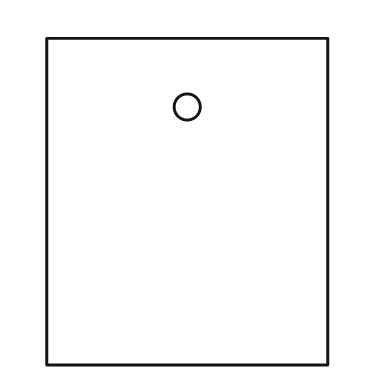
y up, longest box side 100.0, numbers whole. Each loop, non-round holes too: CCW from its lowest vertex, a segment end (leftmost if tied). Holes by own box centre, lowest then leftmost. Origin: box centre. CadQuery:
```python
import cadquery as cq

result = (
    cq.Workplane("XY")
    .moveTo(-43.0, -50.0)
    .lineTo(43.0, -50.0)
    .lineTo(43.0, 50.0)
    .lineTo(-43.0, 50.0)
    .close()
    .moveTo(0.0, 29.0)
    .circle(4.0)
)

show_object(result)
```